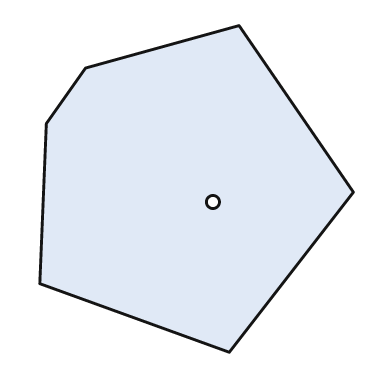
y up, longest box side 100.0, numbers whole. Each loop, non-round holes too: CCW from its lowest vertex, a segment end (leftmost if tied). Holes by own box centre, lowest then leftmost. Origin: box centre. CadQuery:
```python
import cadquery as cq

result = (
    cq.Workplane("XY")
    .moveTo(10.0, -50.0)
    .lineTo(48.0, -1.0)
    .lineTo(13.0, 50.0)
    .lineTo(-34.0, 37.0)
    .lineTo(-46.0, 20.0)
    .lineTo(-48.0, -29.0)
    .close()
    .moveTo(5.0, -4.0)
    .circle(2.0)
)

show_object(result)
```